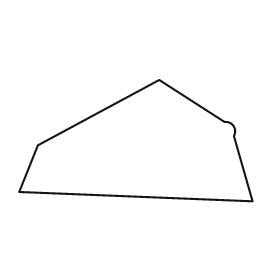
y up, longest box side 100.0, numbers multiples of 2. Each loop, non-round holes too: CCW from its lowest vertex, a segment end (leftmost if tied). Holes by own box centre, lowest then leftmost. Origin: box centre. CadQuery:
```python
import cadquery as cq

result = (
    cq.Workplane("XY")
    .moveTo(50.0, -26.0)
    .lineTo(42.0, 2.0)
    .threePointArc((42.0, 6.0), (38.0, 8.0))
    .lineTo(10.0, 26.0)
    .lineTo(-42.0, -2.0)
    .lineTo(-50.0, -22.0)
    .close()
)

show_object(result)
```